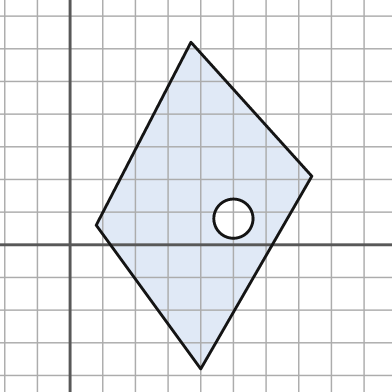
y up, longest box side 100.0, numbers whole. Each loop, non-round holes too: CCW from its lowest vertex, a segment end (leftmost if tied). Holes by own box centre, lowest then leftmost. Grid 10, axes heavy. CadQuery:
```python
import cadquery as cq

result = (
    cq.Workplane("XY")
    .moveTo(40.0, -38.0)
    .lineTo(74.0, 21.0)
    .lineTo(37.0, 62.0)
    .lineTo(8.0, 6.0)
    .close()
    .moveTo(50.0, 8.0)
    .circle(6.0)
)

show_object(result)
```